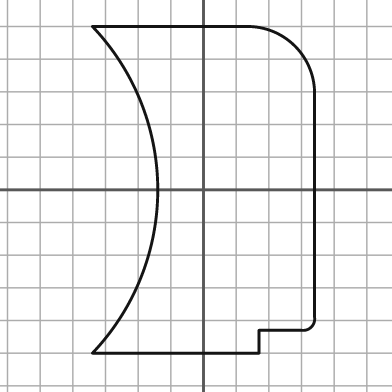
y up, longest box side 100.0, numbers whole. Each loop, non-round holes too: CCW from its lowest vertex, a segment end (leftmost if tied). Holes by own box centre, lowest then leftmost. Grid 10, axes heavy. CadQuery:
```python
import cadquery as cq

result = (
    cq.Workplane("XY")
    .moveTo(-34.0, -50.0)
    .lineTo(17.0, -50.0)
    .lineTo(17.0, -43.0)
    .lineTo(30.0, -43.0)
    .threePointArc((33.0, -42.0), (34.0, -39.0))
    .lineTo(34.0, 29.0)
    .threePointArc((28.0, 44.0), (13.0, 50.0))
    .lineTo(-34.0, 50.0)
    .threePointArc((-14.0, 0.0), (-34.0, -50.0))
    .close()
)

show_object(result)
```